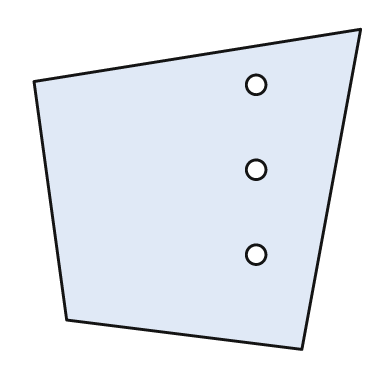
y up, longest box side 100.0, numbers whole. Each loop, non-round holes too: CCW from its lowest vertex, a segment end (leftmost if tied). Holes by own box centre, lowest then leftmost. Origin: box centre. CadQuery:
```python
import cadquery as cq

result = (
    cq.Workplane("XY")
    .moveTo(32.0, -49.0)
    .lineTo(50.0, 49.0)
    .lineTo(-50.0, 33.0)
    .lineTo(-40.0, -40.0)
    .close()
    .moveTo(18.0, -20.0)
    .circle(3.0)
    .moveTo(18.0, 6.0)
    .circle(3.0)
    .moveTo(18.0, 32.0)
    .circle(3.0)
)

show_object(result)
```